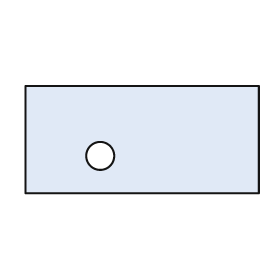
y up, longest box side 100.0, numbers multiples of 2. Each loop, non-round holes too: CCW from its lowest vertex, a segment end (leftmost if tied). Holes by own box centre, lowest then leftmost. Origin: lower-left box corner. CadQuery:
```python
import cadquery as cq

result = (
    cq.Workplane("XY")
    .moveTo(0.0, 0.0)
    .lineTo(100.0, 0.0)
    .lineTo(100.0, 46.0)
    .lineTo(0.0, 46.0)
    .close()
    .moveTo(32.0, 16.0)
    .circle(6.0)
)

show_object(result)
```